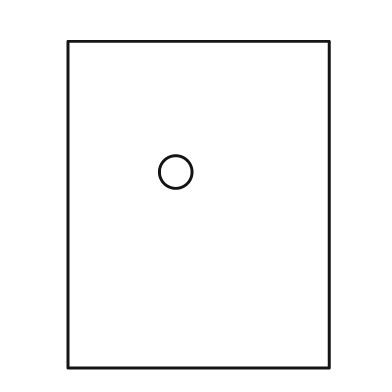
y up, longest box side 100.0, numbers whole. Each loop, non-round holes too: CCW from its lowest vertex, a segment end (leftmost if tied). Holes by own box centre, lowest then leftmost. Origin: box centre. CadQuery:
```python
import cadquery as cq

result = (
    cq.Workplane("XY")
    .moveTo(-40.0, -50.0)
    .lineTo(40.0, -50.0)
    .lineTo(40.0, 50.0)
    .lineTo(-40.0, 50.0)
    .close()
    .moveTo(-7.0, 10.0)
    .circle(5.0)
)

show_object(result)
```